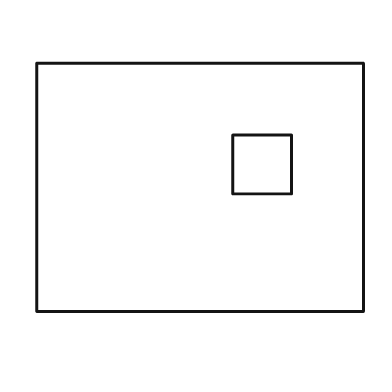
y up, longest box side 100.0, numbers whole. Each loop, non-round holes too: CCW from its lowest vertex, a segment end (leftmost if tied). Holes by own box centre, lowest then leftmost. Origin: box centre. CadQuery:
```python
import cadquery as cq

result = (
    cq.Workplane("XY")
    .moveTo(-50.0, -38.0)
    .lineTo(50.0, -38.0)
    .lineTo(50.0, 38.0)
    .lineTo(-50.0, 38.0)
    .close()
    .moveTo(10.0, -2.0)
    .lineTo(28.0, -2.0)
    .lineTo(28.0, 16.0)
    .lineTo(10.0, 16.0)
    .close()
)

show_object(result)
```